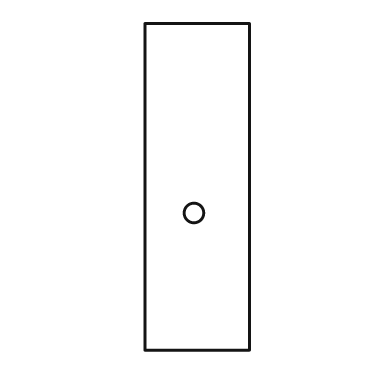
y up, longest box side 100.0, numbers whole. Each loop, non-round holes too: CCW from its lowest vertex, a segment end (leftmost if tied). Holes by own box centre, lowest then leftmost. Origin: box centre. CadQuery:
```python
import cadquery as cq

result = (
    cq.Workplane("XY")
    .moveTo(-16.0, -50.0)
    .lineTo(16.0, -50.0)
    .lineTo(16.0, 50.0)
    .lineTo(-16.0, 50.0)
    .close()
    .moveTo(-1.0, -8.0)
    .circle(3.0)
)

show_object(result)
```